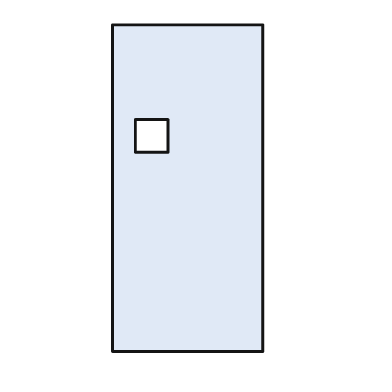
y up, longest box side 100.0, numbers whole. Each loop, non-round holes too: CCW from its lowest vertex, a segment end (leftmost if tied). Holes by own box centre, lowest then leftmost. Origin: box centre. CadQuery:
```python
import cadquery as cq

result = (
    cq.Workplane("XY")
    .moveTo(-23.0, -50.0)
    .lineTo(23.0, -50.0)
    .lineTo(23.0, 50.0)
    .lineTo(-23.0, 50.0)
    .close()
    .moveTo(-16.0, 11.0)
    .lineTo(-6.0, 11.0)
    .lineTo(-6.0, 21.0)
    .lineTo(-16.0, 21.0)
    .close()
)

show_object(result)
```